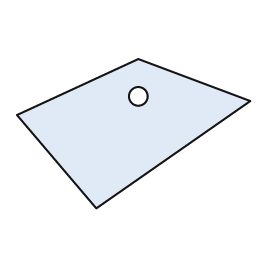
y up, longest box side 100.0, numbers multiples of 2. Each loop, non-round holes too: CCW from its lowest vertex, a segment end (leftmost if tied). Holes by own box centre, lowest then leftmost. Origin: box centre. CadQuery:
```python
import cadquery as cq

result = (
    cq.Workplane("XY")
    .moveTo(-16.0, -32.0)
    .lineTo(50.0, 14.0)
    .lineTo(2.0, 32.0)
    .lineTo(-50.0, 8.0)
    .close()
    .moveTo(2.0, 16.0)
    .circle(4.0)
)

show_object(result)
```